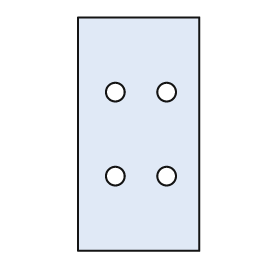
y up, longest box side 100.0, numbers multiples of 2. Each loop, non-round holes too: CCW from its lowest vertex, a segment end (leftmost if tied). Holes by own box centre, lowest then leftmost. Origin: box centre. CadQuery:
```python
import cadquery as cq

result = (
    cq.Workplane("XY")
    .moveTo(-26.0, -50.0)
    .lineTo(26.0, -50.0)
    .lineTo(26.0, 50.0)
    .lineTo(-26.0, 50.0)
    .close()
    .moveTo(-10.0, -18.0)
    .circle(4.0)
    .moveTo(12.0, -18.0)
    .circle(4.0)
    .moveTo(-10.0, 18.0)
    .circle(4.0)
    .moveTo(12.0, 18.0)
    .circle(4.0)
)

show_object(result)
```